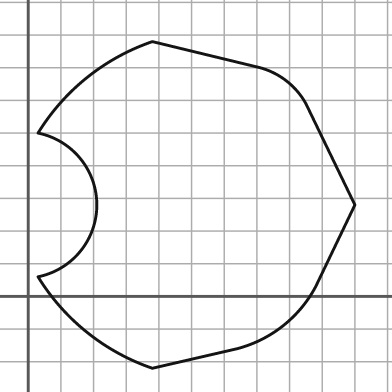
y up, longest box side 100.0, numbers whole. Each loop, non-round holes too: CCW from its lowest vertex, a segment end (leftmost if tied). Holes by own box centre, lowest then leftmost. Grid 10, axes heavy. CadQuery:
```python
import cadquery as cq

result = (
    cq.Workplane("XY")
    .moveTo(38.0, -22.0)
    .lineTo(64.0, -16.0)
    .threePointArc((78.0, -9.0), (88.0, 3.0))
    .lineTo(100.0, 28.0)
    .lineTo(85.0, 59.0)
    .threePointArc((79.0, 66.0), (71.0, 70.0))
    .lineTo(38.0, 78.0)
    .threePointArc((18.0, 67.0), (3.0, 50.0))
    .threePointArc((21.0, 28.0), (3.0, 6.0))
    .threePointArc((18.0, -11.0), (38.0, -22.0))
    .close()
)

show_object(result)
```